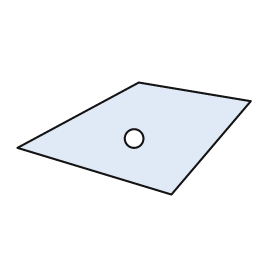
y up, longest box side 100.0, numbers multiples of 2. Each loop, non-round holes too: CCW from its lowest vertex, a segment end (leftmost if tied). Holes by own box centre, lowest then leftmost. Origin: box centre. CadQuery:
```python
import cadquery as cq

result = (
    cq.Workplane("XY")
    .moveTo(16.0, -24.0)
    .lineTo(50.0, 16.0)
    .lineTo(2.0, 24.0)
    .lineTo(-50.0, -4.0)
    .close()
    .moveTo(0.0, 0.0)
    .circle(4.0)
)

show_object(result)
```